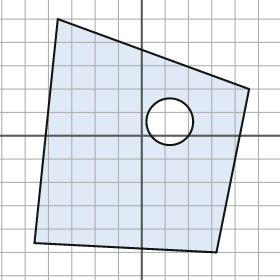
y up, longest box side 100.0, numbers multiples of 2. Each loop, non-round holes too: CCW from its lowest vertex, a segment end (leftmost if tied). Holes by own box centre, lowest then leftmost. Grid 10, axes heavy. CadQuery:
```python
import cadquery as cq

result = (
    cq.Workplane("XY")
    .moveTo(32.0, -50.0)
    .lineTo(46.0, 20.0)
    .lineTo(-36.0, 50.0)
    .lineTo(-46.0, -46.0)
    .close()
    .moveTo(12.0, 6.0)
    .circle(10.0)
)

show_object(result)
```